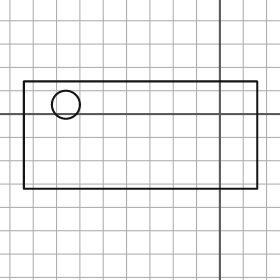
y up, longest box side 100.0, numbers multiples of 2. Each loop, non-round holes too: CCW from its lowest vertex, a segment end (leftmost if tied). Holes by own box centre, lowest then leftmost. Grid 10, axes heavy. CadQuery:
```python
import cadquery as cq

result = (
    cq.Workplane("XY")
    .moveTo(-84.0, -32.0)
    .lineTo(16.0, -32.0)
    .lineTo(16.0, 14.0)
    .lineTo(-84.0, 14.0)
    .close()
    .moveTo(-66.0, 4.0)
    .circle(6.0)
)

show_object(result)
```